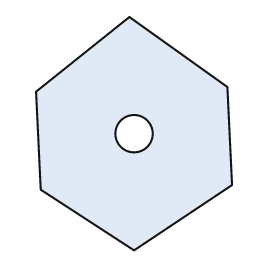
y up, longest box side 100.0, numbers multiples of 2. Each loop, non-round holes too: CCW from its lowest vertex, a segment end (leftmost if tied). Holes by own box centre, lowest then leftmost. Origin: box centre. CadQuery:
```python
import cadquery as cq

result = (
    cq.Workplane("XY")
    .moveTo(0.0, -50.0)
    .lineTo(42.0, -22.0)
    .lineTo(40.0, 20.0)
    .lineTo(-2.0, 50.0)
    .lineTo(-42.0, 18.0)
    .lineTo(-40.0, -24.0)
    .close()
    .moveTo(0.0, 0.0)
    .circle(8.0)
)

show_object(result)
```